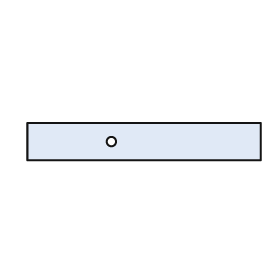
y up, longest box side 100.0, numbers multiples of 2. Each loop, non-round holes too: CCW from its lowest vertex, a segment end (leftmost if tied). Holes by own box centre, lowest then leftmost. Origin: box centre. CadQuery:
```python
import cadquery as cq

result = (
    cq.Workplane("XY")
    .moveTo(-50.0, -8.0)
    .lineTo(50.0, -8.0)
    .lineTo(50.0, 8.0)
    .lineTo(-50.0, 8.0)
    .close()
    .moveTo(-14.0, 0.0)
    .circle(2.0)
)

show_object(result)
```